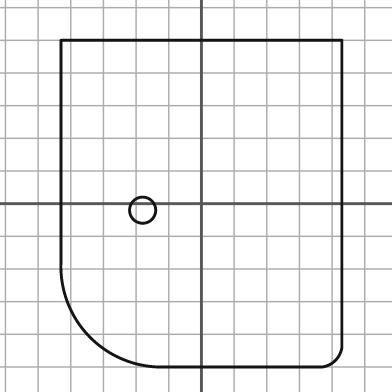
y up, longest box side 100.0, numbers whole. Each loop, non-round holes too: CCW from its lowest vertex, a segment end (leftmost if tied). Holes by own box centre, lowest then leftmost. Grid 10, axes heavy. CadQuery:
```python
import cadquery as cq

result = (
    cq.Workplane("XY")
    .moveTo(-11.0, -50.0)
    .lineTo(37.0, -50.0)
    .threePointArc((41.0, -48.0), (43.0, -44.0))
    .lineTo(43.0, 50.0)
    .lineTo(-43.0, 50.0)
    .lineTo(-43.0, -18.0)
    .threePointArc((-34.0, -41.0), (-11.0, -50.0))
    .close()
    .moveTo(-18.0, -2.0)
    .circle(4.0)
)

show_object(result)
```